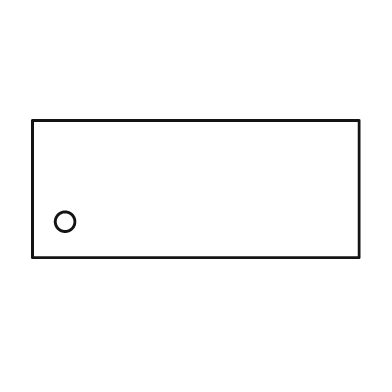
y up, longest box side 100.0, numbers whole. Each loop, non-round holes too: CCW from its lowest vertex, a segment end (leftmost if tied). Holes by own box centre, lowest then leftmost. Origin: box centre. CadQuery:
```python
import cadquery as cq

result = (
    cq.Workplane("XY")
    .moveTo(-50.0, -21.0)
    .lineTo(50.0, -21.0)
    .lineTo(50.0, 21.0)
    .lineTo(-50.0, 21.0)
    .close()
    .moveTo(-40.0, -10.0)
    .circle(3.0)
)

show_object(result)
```